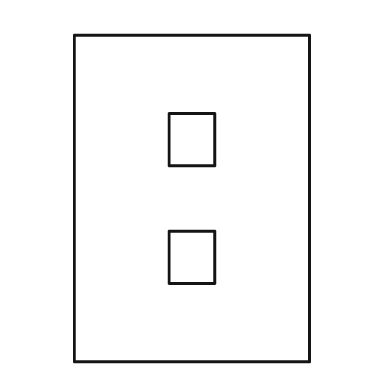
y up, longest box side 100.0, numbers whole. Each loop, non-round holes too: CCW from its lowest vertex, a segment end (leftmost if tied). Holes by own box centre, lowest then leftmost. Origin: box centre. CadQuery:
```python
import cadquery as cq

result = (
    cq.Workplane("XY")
    .moveTo(-36.0, -50.0)
    .lineTo(36.0, -50.0)
    .lineTo(36.0, 50.0)
    .lineTo(-36.0, 50.0)
    .close()
    .moveTo(-7.0, -26.0)
    .lineTo(7.0, -26.0)
    .lineTo(7.0, -10.0)
    .lineTo(-7.0, -10.0)
    .close()
    .moveTo(-7.0, 10.0)
    .lineTo(7.0, 10.0)
    .lineTo(7.0, 26.0)
    .lineTo(-7.0, 26.0)
    .close()
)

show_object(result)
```